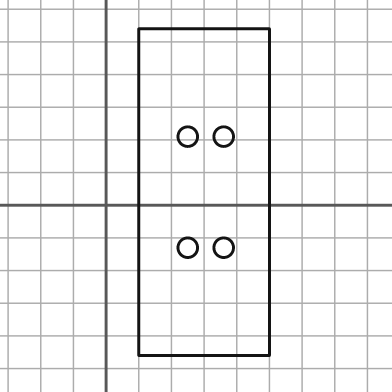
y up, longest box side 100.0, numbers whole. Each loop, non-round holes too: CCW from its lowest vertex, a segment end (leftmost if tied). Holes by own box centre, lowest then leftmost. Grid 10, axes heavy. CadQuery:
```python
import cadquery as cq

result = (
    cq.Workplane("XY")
    .moveTo(10.0, -46.0)
    .lineTo(50.0, -46.0)
    .lineTo(50.0, 54.0)
    .lineTo(10.0, 54.0)
    .close()
    .moveTo(25.0, -13.0)
    .circle(3.0)
    .moveTo(36.0, -13.0)
    .circle(3.0)
    .moveTo(25.0, 21.0)
    .circle(3.0)
    .moveTo(36.0, 21.0)
    .circle(3.0)
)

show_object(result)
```